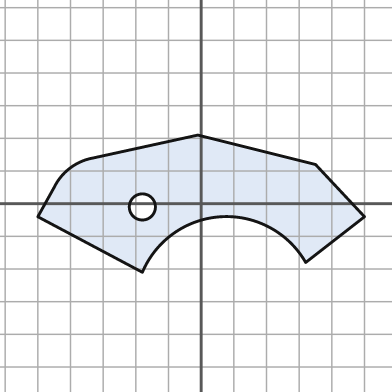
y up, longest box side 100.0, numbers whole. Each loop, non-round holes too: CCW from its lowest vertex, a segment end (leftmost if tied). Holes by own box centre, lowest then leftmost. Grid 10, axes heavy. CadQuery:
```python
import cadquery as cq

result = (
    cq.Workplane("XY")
    .moveTo(-18.0, -21.0)
    .threePointArc((6.0, -4.0), (32.0, -18.0))
    .lineTo(50.0, -4.0)
    .lineTo(35.0, 12.0)
    .lineTo(-1.0, 21.0)
    .lineTo(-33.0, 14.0)
    .threePointArc((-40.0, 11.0), (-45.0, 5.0))
    .lineTo(-50.0, -4.0)
    .close()
    .moveTo(-18.0, -1.0)
    .circle(4.0)
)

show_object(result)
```